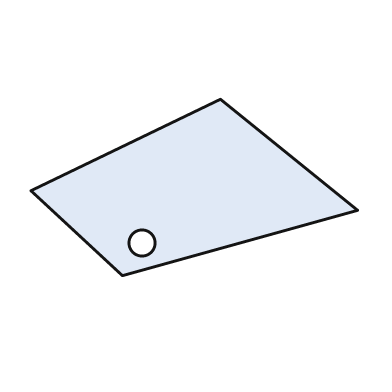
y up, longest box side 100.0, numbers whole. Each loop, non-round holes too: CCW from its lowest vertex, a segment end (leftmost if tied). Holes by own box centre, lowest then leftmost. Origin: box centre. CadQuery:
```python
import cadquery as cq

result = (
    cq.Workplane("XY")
    .moveTo(-22.0, -27.0)
    .lineTo(50.0, -7.0)
    .lineTo(8.0, 27.0)
    .lineTo(-50.0, -1.0)
    .close()
    .moveTo(-16.0, -17.0)
    .circle(4.0)
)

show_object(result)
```